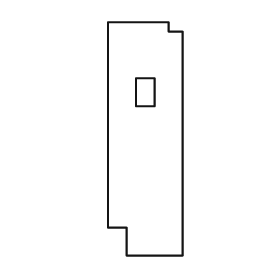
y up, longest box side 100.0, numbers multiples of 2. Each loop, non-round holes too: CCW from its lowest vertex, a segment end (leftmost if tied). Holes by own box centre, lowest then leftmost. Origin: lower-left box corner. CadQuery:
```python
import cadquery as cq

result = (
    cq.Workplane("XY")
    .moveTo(8.0, 0.0)
    .lineTo(32.0, 0.0)
    .lineTo(32.0, 96.0)
    .lineTo(26.0, 96.0)
    .lineTo(26.0, 100.0)
    .lineTo(0.0, 100.0)
    .lineTo(0.0, 12.0)
    .lineTo(8.0, 12.0)
    .close()
    .moveTo(12.0, 64.0)
    .lineTo(20.0, 64.0)
    .lineTo(20.0, 76.0)
    .lineTo(12.0, 76.0)
    .close()
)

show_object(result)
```